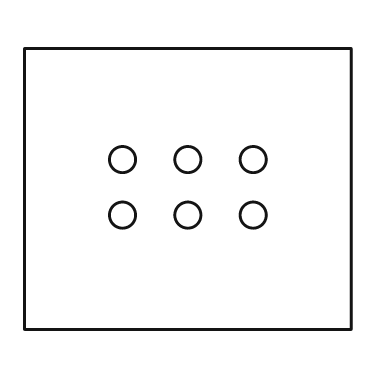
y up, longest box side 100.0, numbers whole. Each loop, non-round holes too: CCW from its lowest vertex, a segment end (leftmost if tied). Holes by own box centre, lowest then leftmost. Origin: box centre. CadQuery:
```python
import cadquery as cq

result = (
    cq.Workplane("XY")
    .moveTo(-50.0, -43.0)
    .lineTo(50.0, -43.0)
    .lineTo(50.0, 43.0)
    .lineTo(-50.0, 43.0)
    .close()
    .moveTo(-20.0, -8.0)
    .circle(4.0)
    .moveTo(0.0, -8.0)
    .circle(4.0)
    .moveTo(20.0, -8.0)
    .circle(4.0)
    .moveTo(-20.0, 9.0)
    .circle(4.0)
    .moveTo(0.0, 9.0)
    .circle(4.0)
    .moveTo(20.0, 9.0)
    .circle(4.0)
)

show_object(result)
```